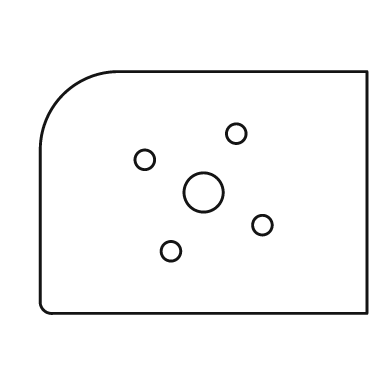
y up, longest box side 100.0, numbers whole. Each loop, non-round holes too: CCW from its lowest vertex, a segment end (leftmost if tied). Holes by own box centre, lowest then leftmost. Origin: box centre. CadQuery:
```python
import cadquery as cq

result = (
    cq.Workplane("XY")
    .moveTo(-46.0, -37.0)
    .lineTo(50.0, -37.0)
    .lineTo(50.0, 37.0)
    .lineTo(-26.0, 37.0)
    .threePointArc((-43.0, 30.0), (-50.0, 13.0))
    .lineTo(-50.0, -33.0)
    .threePointArc((-49.0, -36.0), (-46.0, -37.0))
    .close()
    .moveTo(-10.0, -18.0)
    .circle(3.0)
    .moveTo(18.0, -10.0)
    .circle(3.0)
    .moveTo(0.0, 0.0)
    .circle(6.0)
    .moveTo(-18.0, 10.0)
    .circle(3.0)
    .moveTo(10.0, 18.0)
    .circle(3.0)
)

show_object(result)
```